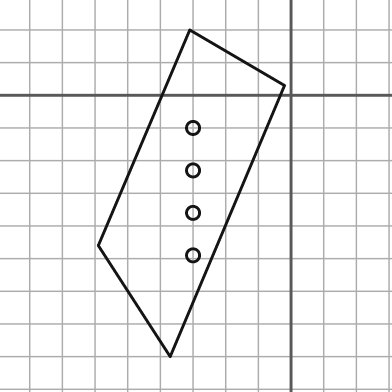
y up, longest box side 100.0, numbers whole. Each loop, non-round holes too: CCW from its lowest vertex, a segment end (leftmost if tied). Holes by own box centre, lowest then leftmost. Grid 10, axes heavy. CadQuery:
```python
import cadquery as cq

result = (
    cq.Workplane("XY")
    .moveTo(-37.0, -80.0)
    .lineTo(-2.0, 3.0)
    .lineTo(-31.0, 20.0)
    .lineTo(-59.0, -46.0)
    .close()
    .moveTo(-30.0, -49.0)
    .circle(2.0)
    .moveTo(-30.0, -36.0)
    .circle(2.0)
    .moveTo(-30.0, -23.0)
    .circle(2.0)
    .moveTo(-30.0, -10.0)
    .circle(2.0)
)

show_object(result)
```